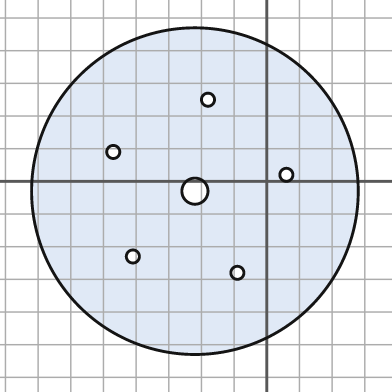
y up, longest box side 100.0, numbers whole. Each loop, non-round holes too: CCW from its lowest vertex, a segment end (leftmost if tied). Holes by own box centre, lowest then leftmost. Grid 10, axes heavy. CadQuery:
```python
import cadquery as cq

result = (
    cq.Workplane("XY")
    .moveTo(-22.0, -3.0)
    .circle(50.0)
    .moveTo(-9.0, -28.0)
    .circle(2.0)
    .moveTo(-41.0, -23.0)
    .circle(2.0)
    .moveTo(-22.0, -3.0)
    .circle(4.0)
    .moveTo(6.0, 2.0)
    .circle(2.0)
    .moveTo(-47.0, 9.0)
    .circle(2.0)
    .moveTo(-18.0, 25.0)
    .circle(2.0)
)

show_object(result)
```